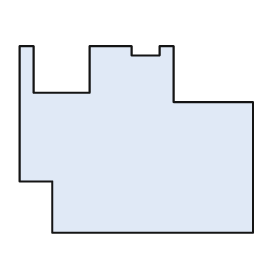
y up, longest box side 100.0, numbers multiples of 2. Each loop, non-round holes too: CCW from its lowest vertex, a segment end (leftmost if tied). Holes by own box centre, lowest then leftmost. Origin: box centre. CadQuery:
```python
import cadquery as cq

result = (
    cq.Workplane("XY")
    .moveTo(-36.0, -40.0)
    .lineTo(50.0, -40.0)
    .lineTo(50.0, 16.0)
    .lineTo(16.0, 16.0)
    .lineTo(16.0, 40.0)
    .lineTo(10.0, 40.0)
    .lineTo(10.0, 36.0)
    .lineTo(-2.0, 36.0)
    .lineTo(-2.0, 40.0)
    .lineTo(-20.0, 40.0)
    .lineTo(-20.0, 20.0)
    .lineTo(-44.0, 20.0)
    .lineTo(-44.0, 40.0)
    .lineTo(-50.0, 40.0)
    .lineTo(-50.0, -18.0)
    .lineTo(-36.0, -18.0)
    .close()
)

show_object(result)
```